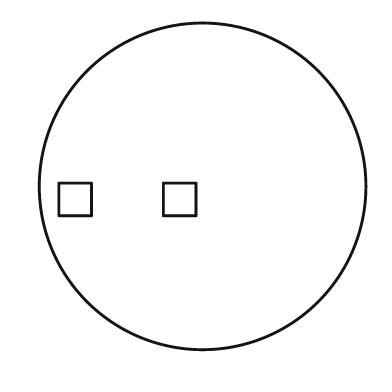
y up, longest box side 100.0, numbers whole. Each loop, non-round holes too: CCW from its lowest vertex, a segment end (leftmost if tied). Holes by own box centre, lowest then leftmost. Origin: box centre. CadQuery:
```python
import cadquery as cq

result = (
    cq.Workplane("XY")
    .moveTo(0.0, 0.0)
    .circle(50.0)
    .moveTo(-44.0, -9.0)
    .lineTo(-34.0, -9.0)
    .lineTo(-34.0, 1.0)
    .lineTo(-44.0, 1.0)
    .close()
    .moveTo(-12.0, -9.0)
    .lineTo(-2.0, -9.0)
    .lineTo(-2.0, 1.0)
    .lineTo(-12.0, 1.0)
    .close()
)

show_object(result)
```